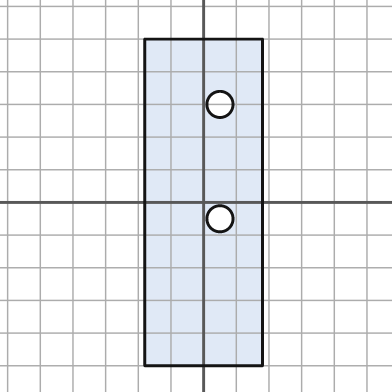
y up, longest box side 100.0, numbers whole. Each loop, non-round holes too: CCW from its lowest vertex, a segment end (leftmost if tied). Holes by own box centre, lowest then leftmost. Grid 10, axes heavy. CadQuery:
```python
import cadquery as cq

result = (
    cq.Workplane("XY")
    .moveTo(-18.0, -50.0)
    .lineTo(18.0, -50.0)
    .lineTo(18.0, 50.0)
    .lineTo(-18.0, 50.0)
    .close()
    .moveTo(5.0, -5.0)
    .circle(4.0)
    .moveTo(5.0, 30.0)
    .circle(4.0)
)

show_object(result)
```